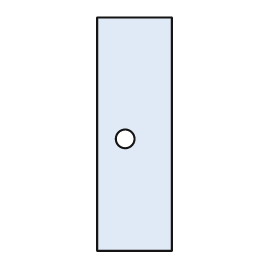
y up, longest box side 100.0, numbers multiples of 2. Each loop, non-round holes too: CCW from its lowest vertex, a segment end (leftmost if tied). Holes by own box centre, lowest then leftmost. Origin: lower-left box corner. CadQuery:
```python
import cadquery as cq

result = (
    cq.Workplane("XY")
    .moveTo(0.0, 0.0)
    .lineTo(32.0, 0.0)
    .lineTo(32.0, 100.0)
    .lineTo(0.0, 100.0)
    .close()
    .moveTo(12.0, 48.0)
    .circle(4.0)
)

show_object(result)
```